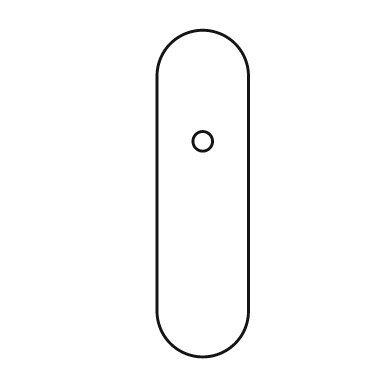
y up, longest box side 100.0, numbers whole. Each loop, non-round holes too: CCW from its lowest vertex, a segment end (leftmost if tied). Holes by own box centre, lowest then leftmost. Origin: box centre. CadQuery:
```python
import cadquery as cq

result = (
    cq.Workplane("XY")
    .moveTo(-14.0, -36.0)
    .threePointArc((0.0, -50.0), (14.0, -36.0))
    .lineTo(14.0, 36.0)
    .threePointArc((0.0, 50.0), (-14.0, 36.0))
    .close()
    .moveTo(0.0, 16.0)
    .circle(3.0)
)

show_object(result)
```